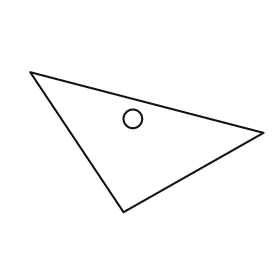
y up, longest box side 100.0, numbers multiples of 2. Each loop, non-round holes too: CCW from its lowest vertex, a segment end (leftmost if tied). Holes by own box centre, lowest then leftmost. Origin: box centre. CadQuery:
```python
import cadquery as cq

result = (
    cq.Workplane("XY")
    .moveTo(-10.0, -30.0)
    .lineTo(50.0, 4.0)
    .lineTo(-50.0, 30.0)
    .close()
    .moveTo(-6.0, 10.0)
    .circle(4.0)
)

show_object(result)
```